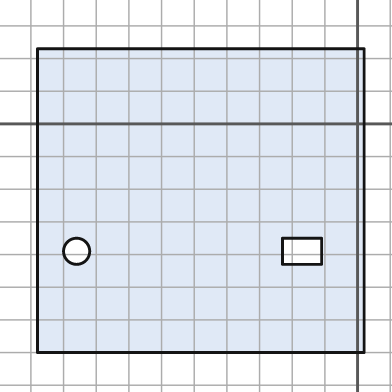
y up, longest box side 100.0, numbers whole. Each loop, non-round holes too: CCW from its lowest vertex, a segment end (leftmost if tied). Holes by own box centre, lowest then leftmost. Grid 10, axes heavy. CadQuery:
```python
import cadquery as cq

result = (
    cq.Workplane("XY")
    .moveTo(-98.0, -70.0)
    .lineTo(2.0, -70.0)
    .lineTo(2.0, 23.0)
    .lineTo(-98.0, 23.0)
    .close()
    .moveTo(-86.0, -39.0)
    .circle(4.0)
    .moveTo(-23.0, -43.0)
    .lineTo(-11.0, -43.0)
    .lineTo(-11.0, -35.0)
    .lineTo(-23.0, -35.0)
    .close()
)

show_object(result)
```